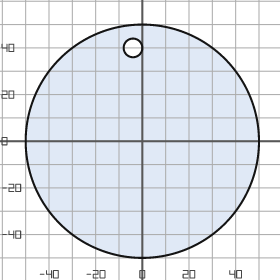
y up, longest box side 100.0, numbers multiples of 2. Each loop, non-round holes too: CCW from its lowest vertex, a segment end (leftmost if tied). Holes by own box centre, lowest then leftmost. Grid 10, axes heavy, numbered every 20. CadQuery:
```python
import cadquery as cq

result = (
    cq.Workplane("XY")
    .moveTo(0.0, 0.0)
    .circle(50.0)
    .moveTo(-4.0, 40.0)
    .circle(4.0)
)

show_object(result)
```